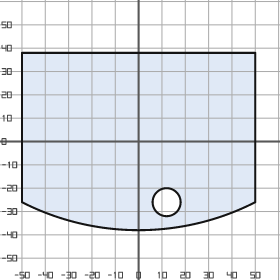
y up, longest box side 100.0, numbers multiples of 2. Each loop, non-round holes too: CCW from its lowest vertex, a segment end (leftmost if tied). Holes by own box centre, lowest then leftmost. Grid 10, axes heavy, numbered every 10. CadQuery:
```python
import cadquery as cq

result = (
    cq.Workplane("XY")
    .moveTo(-50.0, -26.0)
    .threePointArc((0.0, -38.0), (50.0, -26.0))
    .lineTo(50.0, 38.0)
    .lineTo(-50.0, 38.0)
    .close()
    .moveTo(12.0, -26.0)
    .circle(6.0)
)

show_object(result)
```